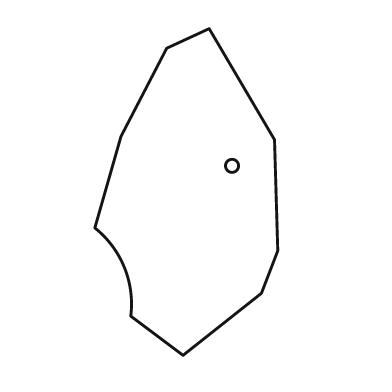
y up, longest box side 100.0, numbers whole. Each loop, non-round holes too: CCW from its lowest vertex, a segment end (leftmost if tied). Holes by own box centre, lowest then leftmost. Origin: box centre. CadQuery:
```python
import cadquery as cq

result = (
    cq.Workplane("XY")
    .moveTo(-1.0, -50.0)
    .lineTo(23.0, -31.0)
    .lineTo(28.0, -18.0)
    .lineTo(27.0, 16.0)
    .lineTo(7.0, 50.0)
    .lineTo(-6.0, 44.0)
    .lineTo(-20.0, 17.0)
    .lineTo(-28.0, -11.0)
    .threePointArc((-19.0, -23.0), (-17.0, -38.0))
    .close()
    .moveTo(14.0, 8.0)
    .circle(2.0)
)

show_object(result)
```